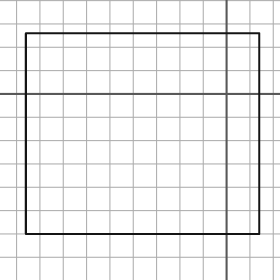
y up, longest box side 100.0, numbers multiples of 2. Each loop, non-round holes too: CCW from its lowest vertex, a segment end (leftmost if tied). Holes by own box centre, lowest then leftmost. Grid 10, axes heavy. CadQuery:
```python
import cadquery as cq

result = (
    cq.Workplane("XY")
    .moveTo(-86.0, -60.0)
    .lineTo(14.0, -60.0)
    .lineTo(14.0, 26.0)
    .lineTo(-86.0, 26.0)
    .close()
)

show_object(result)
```